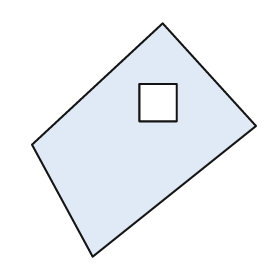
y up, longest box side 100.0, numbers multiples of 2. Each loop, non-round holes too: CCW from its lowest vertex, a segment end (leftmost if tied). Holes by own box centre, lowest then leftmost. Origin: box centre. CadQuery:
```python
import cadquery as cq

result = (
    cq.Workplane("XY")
    .moveTo(-22.0, -50.0)
    .lineTo(48.0, 6.0)
    .lineTo(8.0, 50.0)
    .lineTo(-48.0, -2.0)
    .close()
    .moveTo(-2.0, 8.0)
    .lineTo(14.0, 8.0)
    .lineTo(14.0, 24.0)
    .lineTo(-2.0, 24.0)
    .close()
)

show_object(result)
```